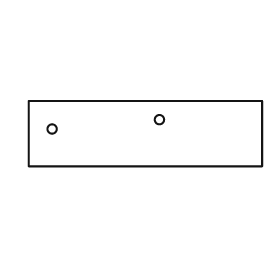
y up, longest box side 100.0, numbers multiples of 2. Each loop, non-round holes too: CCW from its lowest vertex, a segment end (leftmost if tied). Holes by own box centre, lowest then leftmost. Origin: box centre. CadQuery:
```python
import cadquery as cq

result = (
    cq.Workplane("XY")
    .moveTo(-50.0, -14.0)
    .lineTo(50.0, -14.0)
    .lineTo(50.0, 14.0)
    .lineTo(-50.0, 14.0)
    .close()
    .moveTo(-40.0, 2.0)
    .circle(2.0)
    .moveTo(6.0, 6.0)
    .circle(2.0)
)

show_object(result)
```